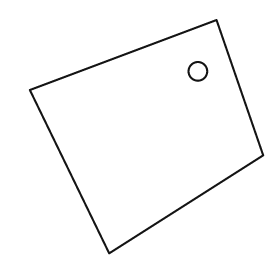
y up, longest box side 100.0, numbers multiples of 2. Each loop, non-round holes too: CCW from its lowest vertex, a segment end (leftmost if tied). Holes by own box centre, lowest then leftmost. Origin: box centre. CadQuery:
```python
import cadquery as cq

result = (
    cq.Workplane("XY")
    .moveTo(-16.0, -50.0)
    .lineTo(50.0, -8.0)
    .lineTo(30.0, 50.0)
    .lineTo(-50.0, 20.0)
    .close()
    .moveTo(22.0, 28.0)
    .circle(4.0)
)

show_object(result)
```